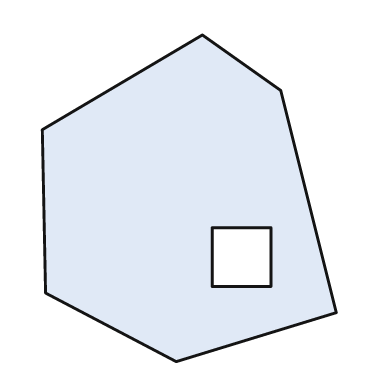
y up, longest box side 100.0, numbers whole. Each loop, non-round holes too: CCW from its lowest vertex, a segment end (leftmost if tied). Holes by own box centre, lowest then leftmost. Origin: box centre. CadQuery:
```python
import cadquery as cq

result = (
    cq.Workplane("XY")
    .moveTo(-4.0, -50.0)
    .lineTo(45.0, -35.0)
    .lineTo(28.0, 33.0)
    .lineTo(4.0, 50.0)
    .lineTo(-45.0, 21.0)
    .lineTo(-44.0, -29.0)
    .close()
    .moveTo(7.0, -27.0)
    .lineTo(25.0, -27.0)
    .lineTo(25.0, -9.0)
    .lineTo(7.0, -9.0)
    .close()
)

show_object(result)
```